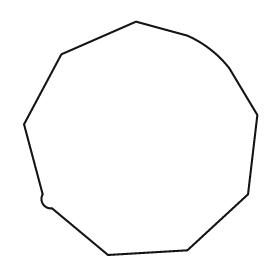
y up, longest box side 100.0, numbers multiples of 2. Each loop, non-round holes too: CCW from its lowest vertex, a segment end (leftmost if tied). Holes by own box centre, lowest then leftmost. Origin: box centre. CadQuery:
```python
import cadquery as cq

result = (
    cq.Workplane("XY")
    .moveTo(-14.0, -50.0)
    .lineTo(20.0, -48.0)
    .lineTo(46.0, -24.0)
    .lineTo(50.0, 10.0)
    .lineTo(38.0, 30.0)
    .threePointArc((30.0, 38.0), (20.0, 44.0))
    .lineTo(-2.0, 50.0)
    .lineTo(-34.0, 36.0)
    .lineTo(-50.0, 6.0)
    .lineTo(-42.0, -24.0)
    .threePointArc((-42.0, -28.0), (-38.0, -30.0))
    .close()
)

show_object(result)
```